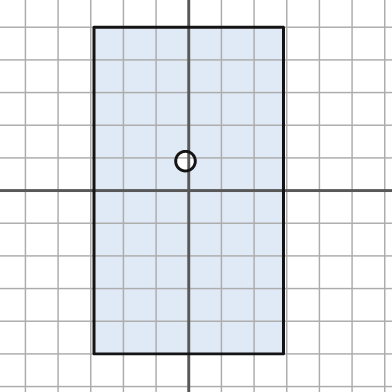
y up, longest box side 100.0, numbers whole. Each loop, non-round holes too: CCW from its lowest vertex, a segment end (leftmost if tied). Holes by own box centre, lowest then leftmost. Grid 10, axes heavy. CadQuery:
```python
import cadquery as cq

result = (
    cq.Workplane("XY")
    .moveTo(-29.0, -50.0)
    .lineTo(29.0, -50.0)
    .lineTo(29.0, 50.0)
    .lineTo(-29.0, 50.0)
    .close()
    .moveTo(-1.0, 9.0)
    .circle(3.0)
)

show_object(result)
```